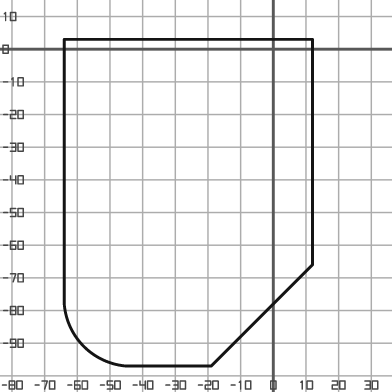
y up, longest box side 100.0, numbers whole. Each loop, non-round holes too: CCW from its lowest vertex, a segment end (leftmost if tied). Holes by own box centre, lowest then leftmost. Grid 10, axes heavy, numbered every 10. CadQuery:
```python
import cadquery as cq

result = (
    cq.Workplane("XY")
    .moveTo(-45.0, -97.0)
    .lineTo(-19.0, -97.0)
    .lineTo(12.0, -66.0)
    .lineTo(12.0, 3.0)
    .lineTo(-64.0, 3.0)
    .lineTo(-64.0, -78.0)
    .threePointArc((-58.0, -91.0), (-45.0, -97.0))
    .close()
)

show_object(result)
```